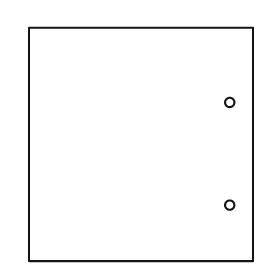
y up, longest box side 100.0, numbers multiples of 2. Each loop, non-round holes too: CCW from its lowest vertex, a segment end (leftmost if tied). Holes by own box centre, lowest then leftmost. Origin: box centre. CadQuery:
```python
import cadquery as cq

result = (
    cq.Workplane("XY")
    .moveTo(-48.0, -50.0)
    .lineTo(48.0, -50.0)
    .lineTo(48.0, 50.0)
    .lineTo(-48.0, 50.0)
    .close()
    .moveTo(38.0, -26.0)
    .circle(2.0)
    .moveTo(38.0, 18.0)
    .circle(2.0)
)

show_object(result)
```